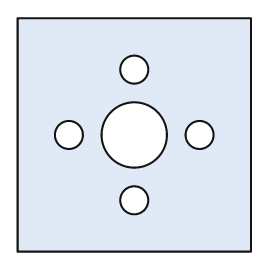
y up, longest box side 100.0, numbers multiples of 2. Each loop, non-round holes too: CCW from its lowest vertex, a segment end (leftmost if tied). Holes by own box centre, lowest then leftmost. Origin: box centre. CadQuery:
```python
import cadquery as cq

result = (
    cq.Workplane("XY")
    .moveTo(-50.0, -50.0)
    .lineTo(50.0, -50.0)
    .lineTo(50.0, 50.0)
    .lineTo(-50.0, 50.0)
    .close()
    .moveTo(0.0, -28.0)
    .circle(6.0)
    .moveTo(-28.0, 0.0)
    .circle(6.0)
    .moveTo(0.0, 0.0)
    .circle(14.0)
    .moveTo(28.0, 0.0)
    .circle(6.0)
    .moveTo(0.0, 28.0)
    .circle(6.0)
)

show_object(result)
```